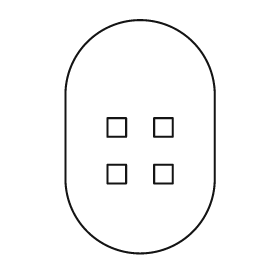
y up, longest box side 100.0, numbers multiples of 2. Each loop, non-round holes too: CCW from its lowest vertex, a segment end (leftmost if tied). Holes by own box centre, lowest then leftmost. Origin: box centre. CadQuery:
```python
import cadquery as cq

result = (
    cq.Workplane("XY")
    .moveTo(-32.0, -18.0)
    .threePointArc((0.0, -50.0), (32.0, -18.0))
    .lineTo(32.0, 18.0)
    .threePointArc((0.0, 50.0), (-32.0, 18.0))
    .close()
    .moveTo(-14.0, -20.0)
    .lineTo(-6.0, -20.0)
    .lineTo(-6.0, -12.0)
    .lineTo(-14.0, -12.0)
    .close()
    .moveTo(6.0, -20.0)
    .lineTo(14.0, -20.0)
    .lineTo(14.0, -12.0)
    .lineTo(6.0, -12.0)
    .close()
    .moveTo(-14.0, 0.0)
    .lineTo(-6.0, 0.0)
    .lineTo(-6.0, 8.0)
    .lineTo(-14.0, 8.0)
    .close()
    .moveTo(6.0, 0.0)
    .lineTo(14.0, 0.0)
    .lineTo(14.0, 8.0)
    .lineTo(6.0, 8.0)
    .close()
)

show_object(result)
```